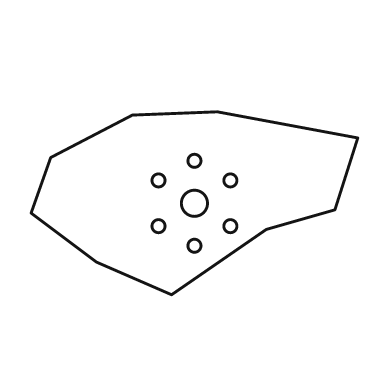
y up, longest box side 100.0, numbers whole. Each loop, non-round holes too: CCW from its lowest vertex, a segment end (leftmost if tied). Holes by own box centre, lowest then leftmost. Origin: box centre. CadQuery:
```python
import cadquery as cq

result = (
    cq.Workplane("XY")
    .moveTo(-7.0, -28.0)
    .lineTo(22.0, -8.0)
    .lineTo(43.0, -2.0)
    .lineTo(50.0, 20.0)
    .lineTo(7.0, 28.0)
    .lineTo(-19.0, 27.0)
    .lineTo(-44.0, 14.0)
    .lineTo(-50.0, -3.0)
    .lineTo(-30.0, -18.0)
    .close()
    .moveTo(0.0, -13.0)
    .circle(2.0)
    .moveTo(-11.0, -7.0)
    .circle(2.0)
    .moveTo(11.0, -7.0)
    .circle(2.0)
    .moveTo(0.0, 0.0)
    .circle(4.0)
    .moveTo(-11.0, 7.0)
    .circle(2.0)
    .moveTo(11.0, 7.0)
    .circle(2.0)
    .moveTo(0.0, 13.0)
    .circle(2.0)
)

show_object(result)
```